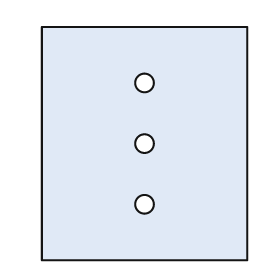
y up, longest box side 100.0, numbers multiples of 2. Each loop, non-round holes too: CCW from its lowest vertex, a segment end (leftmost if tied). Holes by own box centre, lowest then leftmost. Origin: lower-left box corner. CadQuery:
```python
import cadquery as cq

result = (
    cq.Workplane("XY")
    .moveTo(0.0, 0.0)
    .lineTo(88.0, 0.0)
    .lineTo(88.0, 100.0)
    .lineTo(0.0, 100.0)
    .close()
    .moveTo(44.0, 24.0)
    .circle(4.0)
    .moveTo(44.0, 50.0)
    .circle(4.0)
    .moveTo(44.0, 76.0)
    .circle(4.0)
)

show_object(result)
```